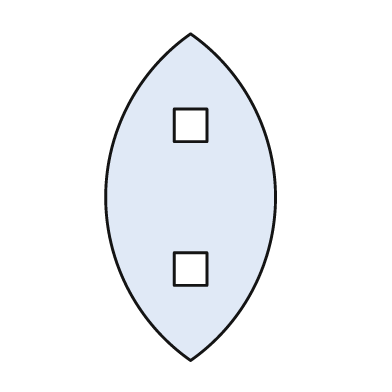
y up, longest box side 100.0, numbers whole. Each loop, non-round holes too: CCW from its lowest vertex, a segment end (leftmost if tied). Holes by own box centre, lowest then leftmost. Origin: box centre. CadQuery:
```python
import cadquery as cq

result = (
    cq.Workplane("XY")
    .moveTo(0.0, -50.0)
    .threePointArc((26.0, 0.0), (0.0, 50.0))
    .threePointArc((-26.0, 0.0), (0.0, -50.0))
    .close()
    .moveTo(-5.0, -27.0)
    .lineTo(5.0, -27.0)
    .lineTo(5.0, -17.0)
    .lineTo(-5.0, -17.0)
    .close()
    .moveTo(-5.0, 17.0)
    .lineTo(5.0, 17.0)
    .lineTo(5.0, 27.0)
    .lineTo(-5.0, 27.0)
    .close()
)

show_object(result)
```